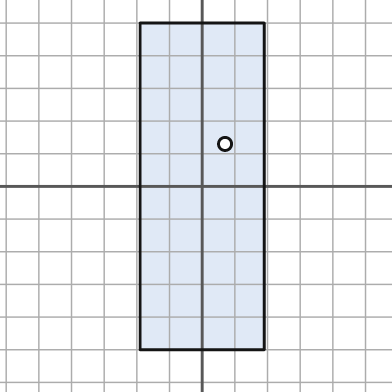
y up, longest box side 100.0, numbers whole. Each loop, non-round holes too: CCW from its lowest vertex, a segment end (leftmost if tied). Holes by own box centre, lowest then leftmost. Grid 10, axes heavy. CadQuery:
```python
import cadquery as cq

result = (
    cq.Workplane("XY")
    .moveTo(-19.0, -50.0)
    .lineTo(19.0, -50.0)
    .lineTo(19.0, 50.0)
    .lineTo(-19.0, 50.0)
    .close()
    .moveTo(7.0, 13.0)
    .circle(2.0)
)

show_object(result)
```